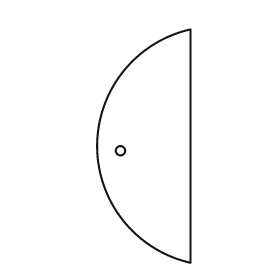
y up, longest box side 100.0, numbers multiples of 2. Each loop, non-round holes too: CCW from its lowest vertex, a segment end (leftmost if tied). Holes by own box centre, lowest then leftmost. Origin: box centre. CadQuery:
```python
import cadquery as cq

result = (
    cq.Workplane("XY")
    .moveTo(20.0, -50.0)
    .lineTo(20.0, 50.0)
    .threePointArc((-20.0, 0.0), (20.0, -50.0))
    .close()
    .moveTo(-10.0, -2.0)
    .circle(2.0)
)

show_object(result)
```